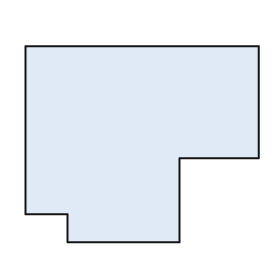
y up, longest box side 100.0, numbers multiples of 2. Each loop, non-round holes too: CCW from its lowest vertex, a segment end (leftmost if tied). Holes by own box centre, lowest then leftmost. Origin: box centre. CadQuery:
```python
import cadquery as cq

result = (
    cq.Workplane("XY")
    .moveTo(-32.0, -42.0)
    .lineTo(16.0, -42.0)
    .lineTo(16.0, -6.0)
    .lineTo(50.0, -6.0)
    .lineTo(50.0, 42.0)
    .lineTo(-50.0, 42.0)
    .lineTo(-50.0, -30.0)
    .lineTo(-32.0, -30.0)
    .close()
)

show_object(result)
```